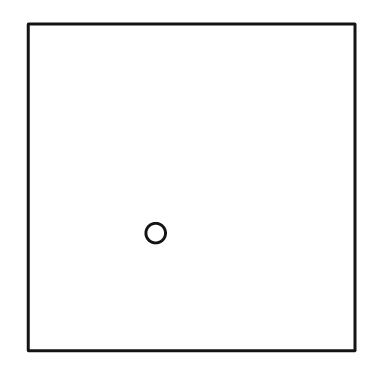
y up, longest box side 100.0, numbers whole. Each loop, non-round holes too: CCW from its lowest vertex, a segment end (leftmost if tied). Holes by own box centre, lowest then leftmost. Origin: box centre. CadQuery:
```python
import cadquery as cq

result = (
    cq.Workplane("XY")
    .moveTo(-50.0, -50.0)
    .lineTo(50.0, -50.0)
    .lineTo(50.0, 50.0)
    .lineTo(-50.0, 50.0)
    .close()
    .moveTo(-11.0, -14.0)
    .circle(3.0)
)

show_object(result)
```